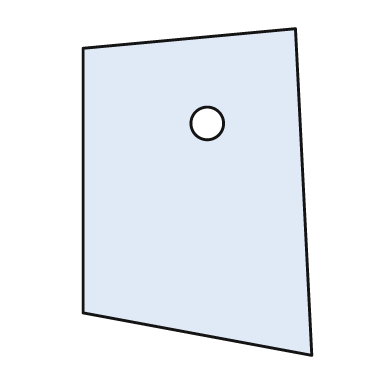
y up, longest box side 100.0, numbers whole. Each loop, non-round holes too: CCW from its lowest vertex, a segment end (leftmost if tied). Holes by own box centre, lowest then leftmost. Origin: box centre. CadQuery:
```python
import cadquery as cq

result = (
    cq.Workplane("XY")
    .moveTo(35.0, -50.0)
    .lineTo(30.0, 50.0)
    .lineTo(-35.0, 44.0)
    .lineTo(-35.0, -37.0)
    .close()
    .moveTo(3.0, 21.0)
    .circle(5.0)
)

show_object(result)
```